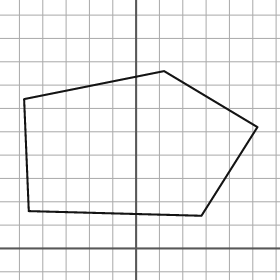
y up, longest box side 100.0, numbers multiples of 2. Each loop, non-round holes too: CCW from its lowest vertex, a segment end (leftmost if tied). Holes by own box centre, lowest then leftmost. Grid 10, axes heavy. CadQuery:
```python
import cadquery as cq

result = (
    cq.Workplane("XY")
    .moveTo(28.0, 14.0)
    .lineTo(52.0, 52.0)
    .lineTo(12.0, 76.0)
    .lineTo(-48.0, 64.0)
    .lineTo(-46.0, 16.0)
    .close()
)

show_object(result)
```